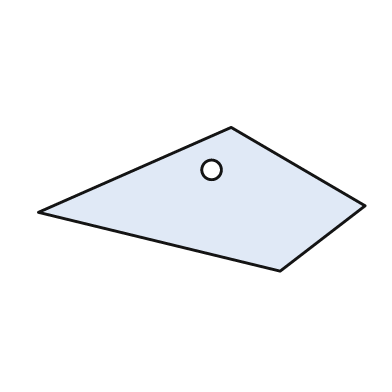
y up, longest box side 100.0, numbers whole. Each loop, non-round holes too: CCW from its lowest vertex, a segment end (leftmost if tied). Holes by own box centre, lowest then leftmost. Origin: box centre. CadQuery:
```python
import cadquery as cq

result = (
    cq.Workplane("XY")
    .moveTo(24.0, -22.0)
    .lineTo(50.0, -2.0)
    .lineTo(9.0, 22.0)
    .lineTo(-50.0, -4.0)
    .close()
    .moveTo(3.0, 9.0)
    .circle(3.0)
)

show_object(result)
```